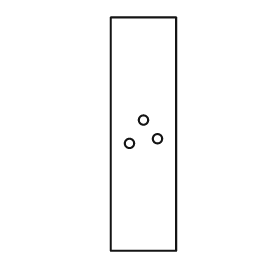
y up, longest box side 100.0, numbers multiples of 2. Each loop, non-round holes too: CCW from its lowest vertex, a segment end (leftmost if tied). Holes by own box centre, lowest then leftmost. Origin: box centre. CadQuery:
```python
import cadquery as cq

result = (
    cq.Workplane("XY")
    .moveTo(-14.0, -50.0)
    .lineTo(14.0, -50.0)
    .lineTo(14.0, 50.0)
    .lineTo(-14.0, 50.0)
    .close()
    .moveTo(-6.0, -4.0)
    .circle(2.0)
    .moveTo(6.0, -2.0)
    .circle(2.0)
    .moveTo(0.0, 6.0)
    .circle(2.0)
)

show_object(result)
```